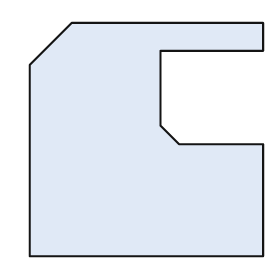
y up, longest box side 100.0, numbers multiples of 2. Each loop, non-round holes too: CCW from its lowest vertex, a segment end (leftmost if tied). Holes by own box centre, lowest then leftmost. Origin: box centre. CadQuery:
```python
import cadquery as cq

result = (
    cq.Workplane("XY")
    .moveTo(-50.0, -50.0)
    .lineTo(50.0, -50.0)
    .lineTo(50.0, -2.0)
    .lineTo(14.0, -2.0)
    .lineTo(6.0, 6.0)
    .lineTo(6.0, 38.0)
    .lineTo(50.0, 38.0)
    .lineTo(50.0, 50.0)
    .lineTo(-32.0, 50.0)
    .lineTo(-50.0, 32.0)
    .close()
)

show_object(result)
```